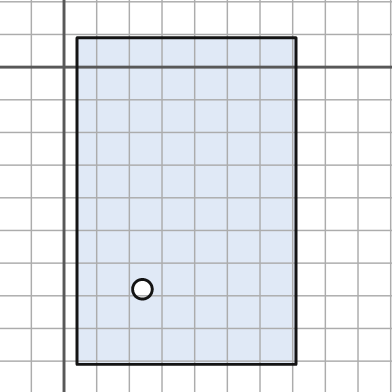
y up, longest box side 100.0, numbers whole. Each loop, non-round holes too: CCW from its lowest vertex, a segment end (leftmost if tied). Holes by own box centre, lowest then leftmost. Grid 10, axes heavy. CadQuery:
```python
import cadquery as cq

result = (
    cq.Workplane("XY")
    .moveTo(4.0, -91.0)
    .lineTo(71.0, -91.0)
    .lineTo(71.0, 9.0)
    .lineTo(4.0, 9.0)
    .close()
    .moveTo(24.0, -68.0)
    .circle(3.0)
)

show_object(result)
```